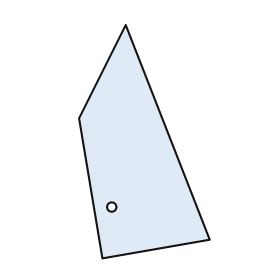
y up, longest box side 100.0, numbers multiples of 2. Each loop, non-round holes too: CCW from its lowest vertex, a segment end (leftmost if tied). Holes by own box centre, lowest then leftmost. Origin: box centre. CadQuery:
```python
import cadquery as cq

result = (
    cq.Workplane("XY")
    .moveTo(-18.0, -50.0)
    .lineTo(28.0, -42.0)
    .lineTo(-8.0, 50.0)
    .lineTo(-28.0, 10.0)
    .close()
    .moveTo(-14.0, -28.0)
    .circle(2.0)
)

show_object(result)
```